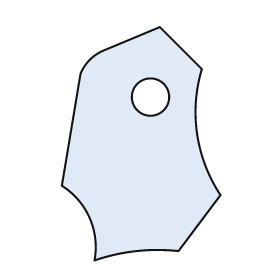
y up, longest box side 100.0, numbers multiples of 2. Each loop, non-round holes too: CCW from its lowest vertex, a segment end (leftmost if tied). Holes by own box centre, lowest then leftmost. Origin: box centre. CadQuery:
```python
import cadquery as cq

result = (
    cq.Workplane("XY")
    .moveTo(-20.0, -50.0)
    .threePointArc((-2.0, -46.0), (16.0, -46.0))
    .lineTo(34.0, -22.0)
    .threePointArc((24.0, 4.0), (26.0, 32.0))
    .lineTo(8.0, 50.0)
    .lineTo(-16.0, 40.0)
    .threePointArc((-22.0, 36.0), (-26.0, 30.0))
    .lineTo(-34.0, -18.0)
    .threePointArc((-22.0, -32.0), (-20.0, -50.0))
    .close()
    .moveTo(4.0, 20.0)
    .circle(8.0)
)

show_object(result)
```